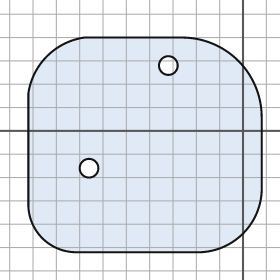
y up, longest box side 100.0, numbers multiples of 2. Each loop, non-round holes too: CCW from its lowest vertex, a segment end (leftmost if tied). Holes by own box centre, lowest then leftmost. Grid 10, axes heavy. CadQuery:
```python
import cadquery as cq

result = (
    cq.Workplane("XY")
    .moveTo(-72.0, -52.0)
    .lineTo(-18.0, -52.0)
    .threePointArc((0.0, -44.0), (8.0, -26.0))
    .lineTo(8.0, 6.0)
    .threePointArc((-2.0, 30.0), (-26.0, 40.0))
    .lineTo(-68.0, 40.0)
    .threePointArc((-84.0, 32.0), (-92.0, 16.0))
    .lineTo(-92.0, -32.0)
    .threePointArc((-86.0, -46.0), (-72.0, -52.0))
    .close()
    .moveTo(-66.0, -16.0)
    .circle(4.0)
    .moveTo(-32.0, 28.0)
    .circle(4.0)
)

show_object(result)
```